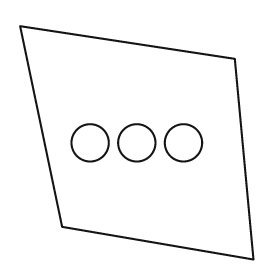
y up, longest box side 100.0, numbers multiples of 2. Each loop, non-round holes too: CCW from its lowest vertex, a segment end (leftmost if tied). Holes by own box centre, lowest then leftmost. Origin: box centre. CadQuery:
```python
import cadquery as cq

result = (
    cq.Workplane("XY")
    .moveTo(50.0, -50.0)
    .lineTo(42.0, 36.0)
    .lineTo(-50.0, 50.0)
    .lineTo(-32.0, -36.0)
    .close()
    .moveTo(-20.0, 0.0)
    .circle(8.0)
    .moveTo(0.0, 0.0)
    .circle(8.0)
    .moveTo(20.0, 0.0)
    .circle(8.0)
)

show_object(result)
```